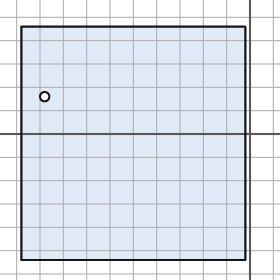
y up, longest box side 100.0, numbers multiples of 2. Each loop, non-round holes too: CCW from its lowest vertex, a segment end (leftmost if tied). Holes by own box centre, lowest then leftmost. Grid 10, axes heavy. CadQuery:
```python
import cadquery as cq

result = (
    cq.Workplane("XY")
    .moveTo(-98.0, -54.0)
    .lineTo(-2.0, -54.0)
    .lineTo(-2.0, 46.0)
    .lineTo(-98.0, 46.0)
    .close()
    .moveTo(-88.0, 16.0)
    .circle(2.0)
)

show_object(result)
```